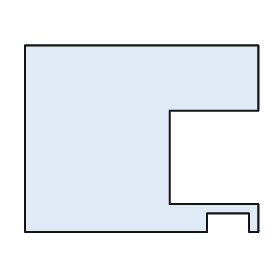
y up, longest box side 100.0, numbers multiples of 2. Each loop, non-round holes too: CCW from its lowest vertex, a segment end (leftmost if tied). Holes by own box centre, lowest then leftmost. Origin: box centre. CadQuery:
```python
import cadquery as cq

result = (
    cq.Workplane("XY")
    .moveTo(-50.0, -40.0)
    .lineTo(28.0, -40.0)
    .lineTo(28.0, -32.0)
    .lineTo(46.0, -32.0)
    .lineTo(46.0, -40.0)
    .lineTo(50.0, -40.0)
    .lineTo(50.0, -28.0)
    .lineTo(12.0, -28.0)
    .lineTo(12.0, 12.0)
    .lineTo(50.0, 12.0)
    .lineTo(50.0, 40.0)
    .lineTo(-50.0, 40.0)
    .close()
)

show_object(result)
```